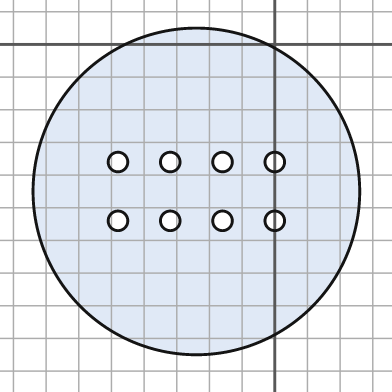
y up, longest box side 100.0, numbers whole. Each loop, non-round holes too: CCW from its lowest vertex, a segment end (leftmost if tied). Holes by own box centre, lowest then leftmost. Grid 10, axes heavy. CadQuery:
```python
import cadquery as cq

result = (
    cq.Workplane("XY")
    .moveTo(-24.0, -45.0)
    .circle(50.0)
    .moveTo(-48.0, -54.0)
    .circle(3.0)
    .moveTo(-32.0, -54.0)
    .circle(3.0)
    .moveTo(-16.0, -54.0)
    .circle(3.0)
    .moveTo(0.0, -54.0)
    .circle(3.0)
    .moveTo(-48.0, -36.0)
    .circle(3.0)
    .moveTo(-32.0, -36.0)
    .circle(3.0)
    .moveTo(-16.0, -36.0)
    .circle(3.0)
    .moveTo(0.0, -36.0)
    .circle(3.0)
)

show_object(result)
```